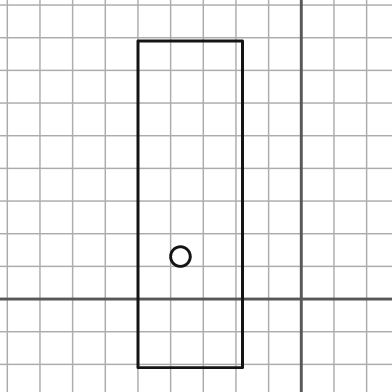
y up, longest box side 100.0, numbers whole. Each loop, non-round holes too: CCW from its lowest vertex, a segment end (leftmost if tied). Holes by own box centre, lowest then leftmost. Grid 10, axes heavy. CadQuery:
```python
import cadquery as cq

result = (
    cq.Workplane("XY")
    .moveTo(-50.0, -21.0)
    .lineTo(-18.0, -21.0)
    .lineTo(-18.0, 79.0)
    .lineTo(-50.0, 79.0)
    .close()
    .moveTo(-37.0, 13.0)
    .circle(3.0)
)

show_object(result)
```